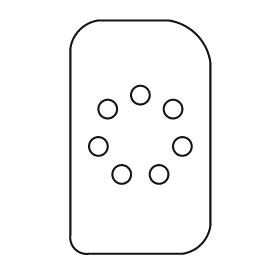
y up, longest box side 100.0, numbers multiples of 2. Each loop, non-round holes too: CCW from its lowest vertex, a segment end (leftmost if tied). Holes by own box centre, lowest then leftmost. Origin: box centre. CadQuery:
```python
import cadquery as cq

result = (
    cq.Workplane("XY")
    .moveTo(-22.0, -50.0)
    .lineTo(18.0, -50.0)
    .threePointArc((26.0, -46.0), (30.0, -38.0))
    .lineTo(30.0, 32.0)
    .threePointArc((24.0, 44.0), (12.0, 50.0))
    .lineTo(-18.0, 50.0)
    .threePointArc((-26.0, 46.0), (-30.0, 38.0))
    .lineTo(-30.0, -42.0)
    .threePointArc((-28.0, -48.0), (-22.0, -50.0))
    .close()
    .moveTo(-8.0, -16.0)
    .circle(4.0)
    .moveTo(8.0, -16.0)
    .circle(4.0)
    .moveTo(-18.0, -4.0)
    .circle(4.0)
    .moveTo(18.0, -4.0)
    .circle(4.0)
    .moveTo(-14.0, 12.0)
    .circle(4.0)
    .moveTo(14.0, 12.0)
    .circle(4.0)
    .moveTo(0.0, 18.0)
    .circle(4.0)
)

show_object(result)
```